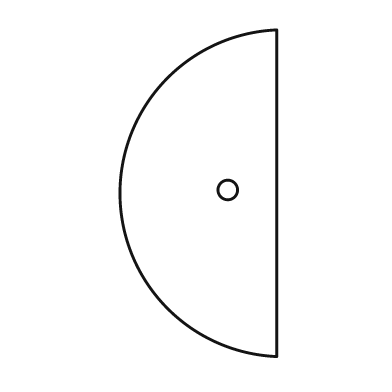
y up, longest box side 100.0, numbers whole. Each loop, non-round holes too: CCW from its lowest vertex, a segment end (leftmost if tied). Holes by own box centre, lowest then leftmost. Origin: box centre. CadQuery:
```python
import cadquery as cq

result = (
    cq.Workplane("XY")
    .moveTo(24.0, -50.0)
    .lineTo(24.0, 50.0)
    .threePointArc((-24.0, 0.0), (24.0, -50.0))
    .close()
    .moveTo(9.0, 1.0)
    .circle(3.0)
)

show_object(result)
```